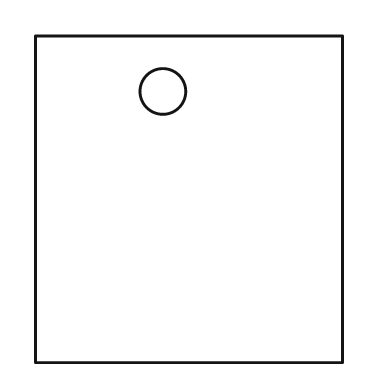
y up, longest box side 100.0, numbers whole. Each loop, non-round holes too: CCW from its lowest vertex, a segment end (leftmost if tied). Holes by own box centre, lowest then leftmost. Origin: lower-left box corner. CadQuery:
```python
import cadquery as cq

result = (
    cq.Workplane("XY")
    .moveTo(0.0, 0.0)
    .lineTo(94.0, 0.0)
    .lineTo(94.0, 100.0)
    .lineTo(0.0, 100.0)
    .close()
    .moveTo(39.0, 83.0)
    .circle(7.0)
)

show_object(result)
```